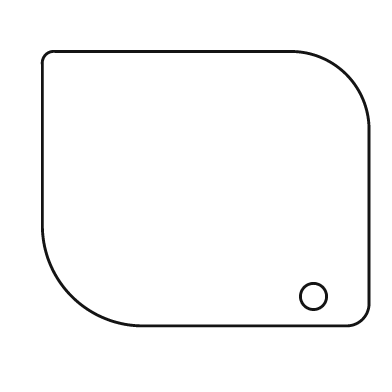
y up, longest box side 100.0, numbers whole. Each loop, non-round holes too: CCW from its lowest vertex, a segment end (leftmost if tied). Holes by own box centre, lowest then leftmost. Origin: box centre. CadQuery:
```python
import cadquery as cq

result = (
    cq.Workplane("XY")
    .moveTo(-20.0, -42.0)
    .lineTo(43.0, -42.0)
    .threePointArc((48.0, -40.0), (50.0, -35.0))
    .lineTo(50.0, 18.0)
    .threePointArc((43.0, 35.0), (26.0, 42.0))
    .lineTo(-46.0, 42.0)
    .threePointArc((-49.0, 41.0), (-50.0, 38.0))
    .lineTo(-50.0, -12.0)
    .threePointArc((-41.0, -33.0), (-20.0, -42.0))
    .close()
    .moveTo(33.0, -33.0)
    .circle(4.0)
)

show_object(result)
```